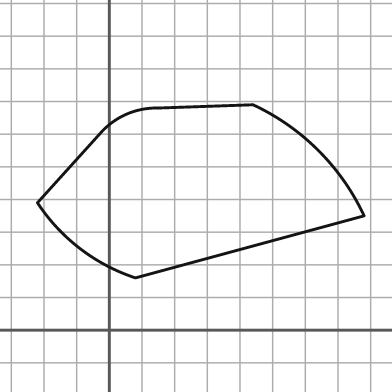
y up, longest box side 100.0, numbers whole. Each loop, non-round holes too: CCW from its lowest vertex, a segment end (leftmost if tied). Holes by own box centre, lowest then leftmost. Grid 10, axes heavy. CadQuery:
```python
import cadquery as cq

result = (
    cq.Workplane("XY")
    .moveTo(8.0, 16.0)
    .lineTo(78.0, 35.0)
    .threePointArc((64.0, 55.0), (44.0, 69.0))
    .lineTo(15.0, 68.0)
    .threePointArc((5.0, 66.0), (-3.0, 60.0))
    .lineTo(-22.0, 39.0)
    .threePointArc((-9.0, 25.0), (8.0, 16.0))
    .close()
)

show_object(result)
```